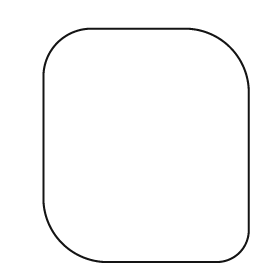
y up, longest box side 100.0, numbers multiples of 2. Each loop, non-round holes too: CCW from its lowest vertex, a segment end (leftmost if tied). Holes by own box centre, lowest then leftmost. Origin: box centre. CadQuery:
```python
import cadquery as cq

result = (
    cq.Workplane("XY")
    .moveTo(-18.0, -50.0)
    .lineTo(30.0, -50.0)
    .threePointArc((40.0, -46.0), (44.0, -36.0))
    .lineTo(44.0, 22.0)
    .threePointArc((36.0, 42.0), (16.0, 50.0))
    .lineTo(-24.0, 50.0)
    .threePointArc((-38.0, 44.0), (-44.0, 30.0))
    .lineTo(-44.0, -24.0)
    .threePointArc((-36.0, -42.0), (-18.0, -50.0))
    .close()
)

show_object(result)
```